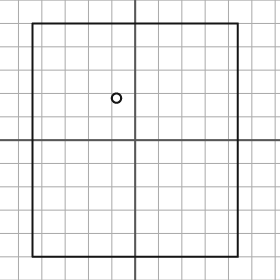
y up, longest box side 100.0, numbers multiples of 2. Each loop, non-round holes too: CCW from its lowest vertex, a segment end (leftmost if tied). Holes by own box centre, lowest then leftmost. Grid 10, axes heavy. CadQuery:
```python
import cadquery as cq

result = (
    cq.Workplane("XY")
    .moveTo(-44.0, -50.0)
    .lineTo(44.0, -50.0)
    .lineTo(44.0, 50.0)
    .lineTo(-44.0, 50.0)
    .close()
    .moveTo(-8.0, 18.0)
    .circle(2.0)
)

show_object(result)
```